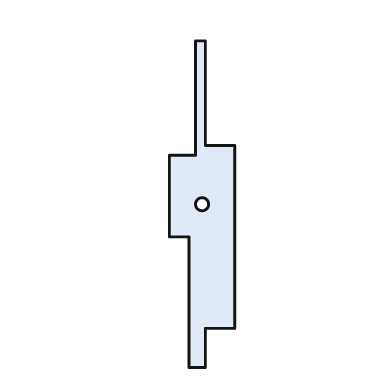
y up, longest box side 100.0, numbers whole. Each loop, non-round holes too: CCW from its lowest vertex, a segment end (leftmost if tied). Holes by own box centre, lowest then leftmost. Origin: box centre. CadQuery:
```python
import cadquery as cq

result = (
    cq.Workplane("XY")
    .moveTo(-4.0, -50.0)
    .lineTo(1.0, -50.0)
    .lineTo(1.0, -38.0)
    .lineTo(10.0, -38.0)
    .lineTo(10.0, 18.0)
    .lineTo(1.0, 18.0)
    .lineTo(1.0, 50.0)
    .lineTo(-2.0, 50.0)
    .lineTo(-2.0, 15.0)
    .lineTo(-10.0, 15.0)
    .lineTo(-10.0, -10.0)
    .lineTo(-4.0, -10.0)
    .close()
    .moveTo(0.0, 0.0)
    .circle(2.0)
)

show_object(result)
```